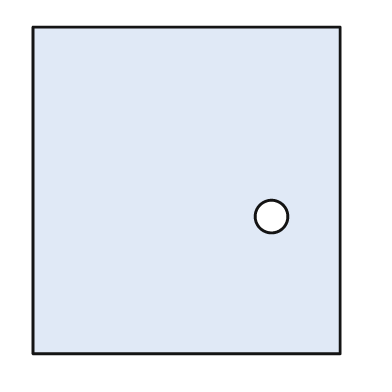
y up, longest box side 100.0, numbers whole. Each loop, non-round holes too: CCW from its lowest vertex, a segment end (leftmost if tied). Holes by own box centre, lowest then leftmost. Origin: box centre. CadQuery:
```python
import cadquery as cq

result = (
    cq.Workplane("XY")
    .moveTo(-47.0, -50.0)
    .lineTo(47.0, -50.0)
    .lineTo(47.0, 50.0)
    .lineTo(-47.0, 50.0)
    .close()
    .moveTo(26.0, -8.0)
    .circle(5.0)
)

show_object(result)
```